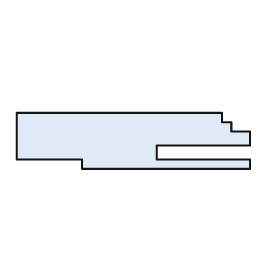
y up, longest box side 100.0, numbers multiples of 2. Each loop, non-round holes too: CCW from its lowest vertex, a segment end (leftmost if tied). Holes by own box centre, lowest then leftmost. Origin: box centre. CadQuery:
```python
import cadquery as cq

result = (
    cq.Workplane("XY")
    .moveTo(-22.0, -12.0)
    .lineTo(50.0, -12.0)
    .lineTo(50.0, -8.0)
    .lineTo(10.0, -8.0)
    .lineTo(10.0, -2.0)
    .lineTo(50.0, -2.0)
    .lineTo(50.0, 4.0)
    .lineTo(42.0, 4.0)
    .lineTo(42.0, 8.0)
    .lineTo(38.0, 8.0)
    .lineTo(38.0, 12.0)
    .lineTo(-50.0, 12.0)
    .lineTo(-50.0, -8.0)
    .lineTo(-22.0, -8.0)
    .close()
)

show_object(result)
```